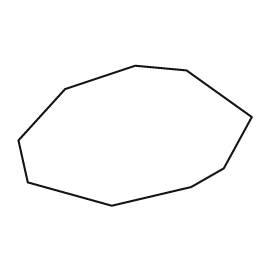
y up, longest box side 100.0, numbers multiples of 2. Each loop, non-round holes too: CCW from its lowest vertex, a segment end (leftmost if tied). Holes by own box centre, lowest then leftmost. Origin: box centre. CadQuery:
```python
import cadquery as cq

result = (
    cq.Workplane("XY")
    .moveTo(-10.0, -30.0)
    .lineTo(24.0, -22.0)
    .lineTo(38.0, -14.0)
    .lineTo(50.0, 8.0)
    .lineTo(22.0, 28.0)
    .lineTo(0.0, 30.0)
    .lineTo(-30.0, 20.0)
    .lineTo(-50.0, -2.0)
    .lineTo(-46.0, -20.0)
    .close()
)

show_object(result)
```